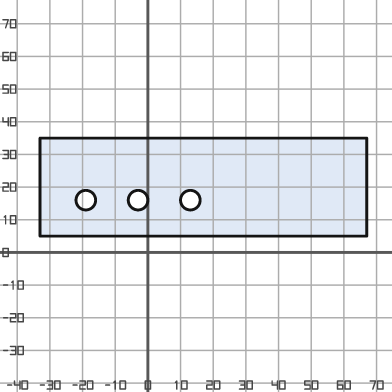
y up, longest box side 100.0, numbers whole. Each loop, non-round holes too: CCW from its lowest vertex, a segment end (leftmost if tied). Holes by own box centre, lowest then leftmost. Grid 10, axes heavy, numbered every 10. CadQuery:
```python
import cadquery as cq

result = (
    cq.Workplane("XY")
    .moveTo(-33.0, 5.0)
    .lineTo(67.0, 5.0)
    .lineTo(67.0, 35.0)
    .lineTo(-33.0, 35.0)
    .close()
    .moveTo(-19.0, 16.0)
    .circle(3.0)
    .moveTo(-3.0, 16.0)
    .circle(3.0)
    .moveTo(13.0, 16.0)
    .circle(3.0)
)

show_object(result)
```